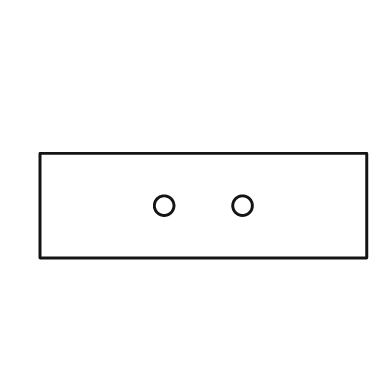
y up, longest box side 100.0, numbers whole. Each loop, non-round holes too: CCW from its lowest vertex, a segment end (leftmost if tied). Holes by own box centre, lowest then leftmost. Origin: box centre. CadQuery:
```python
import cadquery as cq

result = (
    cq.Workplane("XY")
    .moveTo(-50.0, -16.0)
    .lineTo(50.0, -16.0)
    .lineTo(50.0, 16.0)
    .lineTo(-50.0, 16.0)
    .close()
    .moveTo(-12.0, 0.0)
    .circle(3.0)
    .moveTo(12.0, 0.0)
    .circle(3.0)
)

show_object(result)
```